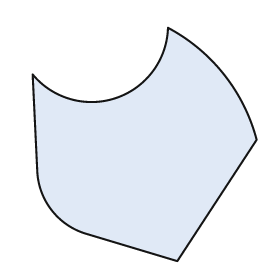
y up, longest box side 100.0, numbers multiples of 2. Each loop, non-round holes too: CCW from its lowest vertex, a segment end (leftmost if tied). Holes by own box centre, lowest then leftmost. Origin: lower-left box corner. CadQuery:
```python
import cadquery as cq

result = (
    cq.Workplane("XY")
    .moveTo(62.0, 0.0)
    .lineTo(96.0, 52.0)
    .threePointArc((82.0, 80.0), (58.0, 100.0))
    .threePointArc((36.0, 70.0), (0.0, 80.0))
    .lineTo(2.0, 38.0)
    .threePointArc((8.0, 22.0), (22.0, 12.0))
    .close()
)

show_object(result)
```